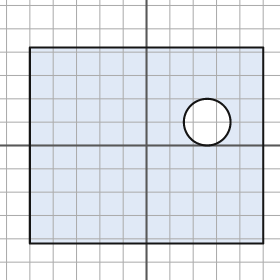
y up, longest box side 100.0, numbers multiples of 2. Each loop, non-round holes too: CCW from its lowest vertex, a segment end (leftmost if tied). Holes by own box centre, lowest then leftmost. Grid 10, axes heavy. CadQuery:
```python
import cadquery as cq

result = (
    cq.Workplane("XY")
    .moveTo(-50.0, -42.0)
    .lineTo(50.0, -42.0)
    .lineTo(50.0, 42.0)
    .lineTo(-50.0, 42.0)
    .close()
    .moveTo(26.0, 10.0)
    .circle(10.0)
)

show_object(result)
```